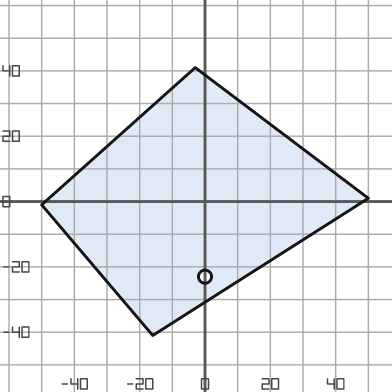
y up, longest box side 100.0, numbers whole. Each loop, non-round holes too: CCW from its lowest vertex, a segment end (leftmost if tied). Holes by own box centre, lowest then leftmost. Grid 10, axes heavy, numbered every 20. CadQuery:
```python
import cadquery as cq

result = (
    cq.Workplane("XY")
    .moveTo(-16.0, -41.0)
    .lineTo(50.0, 1.0)
    .lineTo(-3.0, 41.0)
    .lineTo(-50.0, -1.0)
    .close()
    .moveTo(0.0, -23.0)
    .circle(2.0)
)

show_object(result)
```